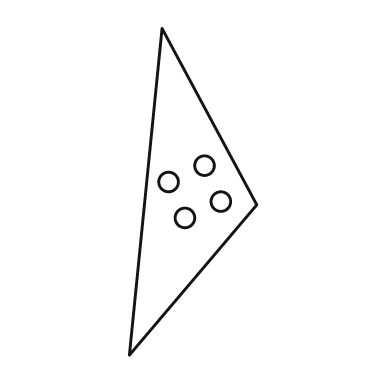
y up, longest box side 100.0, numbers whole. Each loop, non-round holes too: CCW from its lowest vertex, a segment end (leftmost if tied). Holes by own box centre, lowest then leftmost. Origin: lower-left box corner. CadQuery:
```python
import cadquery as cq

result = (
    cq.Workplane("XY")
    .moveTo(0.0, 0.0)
    .lineTo(39.0, 46.0)
    .lineTo(10.0, 100.0)
    .close()
    .moveTo(17.0, 42.0)
    .circle(3.0)
    .moveTo(28.0, 47.0)
    .circle(3.0)
    .moveTo(12.0, 53.0)
    .circle(3.0)
    .moveTo(23.0, 58.0)
    .circle(3.0)
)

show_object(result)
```